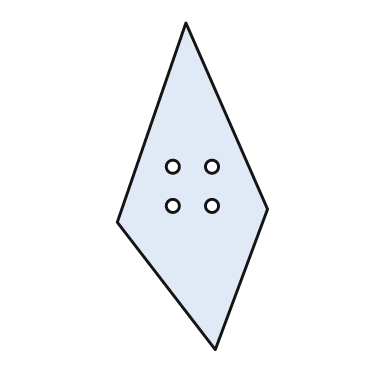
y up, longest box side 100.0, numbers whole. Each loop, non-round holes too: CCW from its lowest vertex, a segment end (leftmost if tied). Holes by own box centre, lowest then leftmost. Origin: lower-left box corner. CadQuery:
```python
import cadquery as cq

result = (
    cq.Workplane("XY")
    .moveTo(30.0, 0.0)
    .lineTo(46.0, 43.0)
    .lineTo(21.0, 100.0)
    .lineTo(0.0, 39.0)
    .close()
    .moveTo(17.0, 44.0)
    .circle(2.0)
    .moveTo(29.0, 44.0)
    .circle(2.0)
    .moveTo(17.0, 56.0)
    .circle(2.0)
    .moveTo(29.0, 56.0)
    .circle(2.0)
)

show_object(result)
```